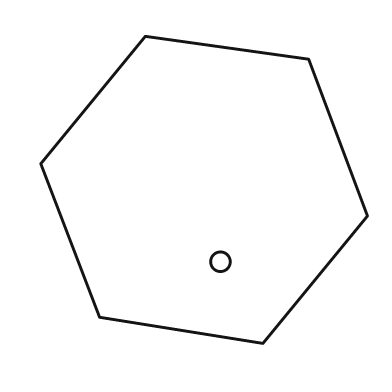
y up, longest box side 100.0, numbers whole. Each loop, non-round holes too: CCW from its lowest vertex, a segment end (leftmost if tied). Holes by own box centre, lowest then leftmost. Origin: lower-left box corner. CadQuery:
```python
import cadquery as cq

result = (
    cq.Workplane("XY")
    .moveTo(68.0, 0.0)
    .lineTo(100.0, 39.0)
    .lineTo(82.0, 87.0)
    .lineTo(32.0, 94.0)
    .lineTo(0.0, 55.0)
    .lineTo(18.0, 8.0)
    .close()
    .moveTo(55.0, 25.0)
    .circle(3.0)
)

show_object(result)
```